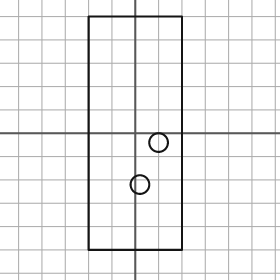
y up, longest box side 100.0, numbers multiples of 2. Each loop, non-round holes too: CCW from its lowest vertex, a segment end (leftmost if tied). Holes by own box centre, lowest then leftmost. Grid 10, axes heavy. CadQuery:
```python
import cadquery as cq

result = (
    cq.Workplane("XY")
    .moveTo(-20.0, -50.0)
    .lineTo(20.0, -50.0)
    .lineTo(20.0, 50.0)
    .lineTo(-20.0, 50.0)
    .close()
    .moveTo(2.0, -22.0)
    .circle(4.0)
    .moveTo(10.0, -4.0)
    .circle(4.0)
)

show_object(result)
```